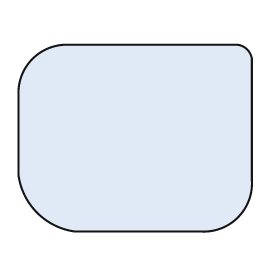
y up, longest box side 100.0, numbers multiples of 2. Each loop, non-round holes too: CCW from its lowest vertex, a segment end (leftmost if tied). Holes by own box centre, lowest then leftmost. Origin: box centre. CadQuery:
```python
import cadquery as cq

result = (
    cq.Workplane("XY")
    .moveTo(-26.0, -40.0)
    .lineTo(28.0, -40.0)
    .threePointArc((44.0, -34.0), (50.0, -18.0))
    .lineTo(50.0, 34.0)
    .threePointArc((48.0, 38.0), (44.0, 40.0))
    .lineTo(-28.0, 40.0)
    .threePointArc((-44.0, 34.0), (-50.0, 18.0))
    .lineTo(-50.0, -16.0)
    .threePointArc((-42.0, -32.0), (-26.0, -40.0))
    .close()
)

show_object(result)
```